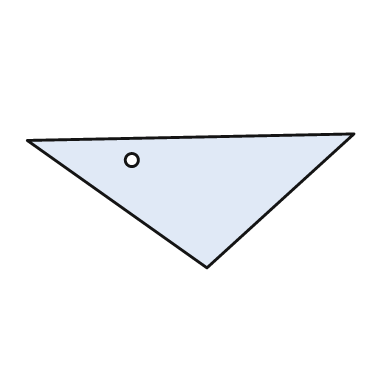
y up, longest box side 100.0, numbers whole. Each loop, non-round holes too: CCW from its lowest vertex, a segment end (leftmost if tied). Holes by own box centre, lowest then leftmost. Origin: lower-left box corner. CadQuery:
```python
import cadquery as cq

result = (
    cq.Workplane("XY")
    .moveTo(55.0, 0.0)
    .lineTo(100.0, 41.0)
    .lineTo(0.0, 39.0)
    .close()
    .moveTo(32.0, 33.0)
    .circle(2.0)
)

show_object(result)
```